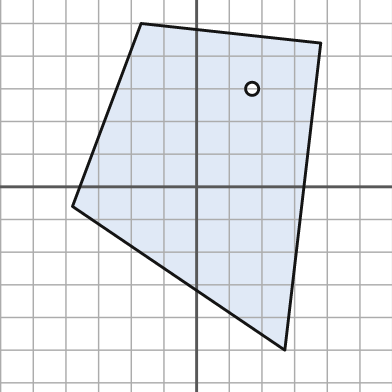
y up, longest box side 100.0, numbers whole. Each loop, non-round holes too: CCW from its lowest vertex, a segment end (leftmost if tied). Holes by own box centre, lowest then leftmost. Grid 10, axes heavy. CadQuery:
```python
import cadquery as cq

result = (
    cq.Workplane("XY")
    .moveTo(27.0, -50.0)
    .lineTo(38.0, 44.0)
    .lineTo(-17.0, 50.0)
    .lineTo(-38.0, -6.0)
    .close()
    .moveTo(17.0, 30.0)
    .circle(2.0)
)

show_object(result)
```